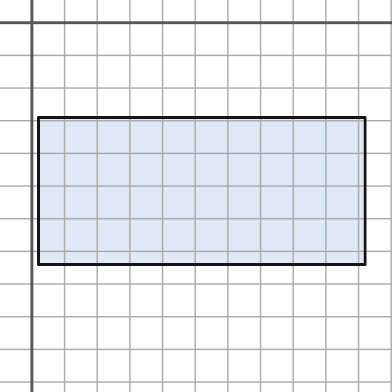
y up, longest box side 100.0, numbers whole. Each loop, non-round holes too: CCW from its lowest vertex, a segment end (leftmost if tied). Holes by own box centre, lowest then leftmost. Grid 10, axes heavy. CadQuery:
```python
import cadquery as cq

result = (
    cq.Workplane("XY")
    .moveTo(2.0, -74.0)
    .lineTo(102.0, -74.0)
    .lineTo(102.0, -29.0)
    .lineTo(2.0, -29.0)
    .close()
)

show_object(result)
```